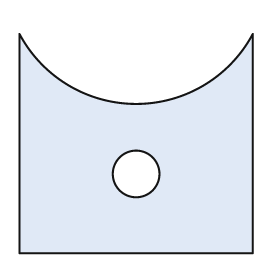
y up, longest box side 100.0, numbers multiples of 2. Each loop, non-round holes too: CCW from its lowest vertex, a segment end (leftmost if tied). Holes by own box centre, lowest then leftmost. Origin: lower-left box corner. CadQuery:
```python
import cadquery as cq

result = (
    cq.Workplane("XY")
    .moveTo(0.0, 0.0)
    .lineTo(100.0, 0.0)
    .lineTo(100.0, 94.0)
    .threePointArc((50.0, 64.0), (0.0, 94.0))
    .close()
    .moveTo(50.0, 34.0)
    .circle(10.0)
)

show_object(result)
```